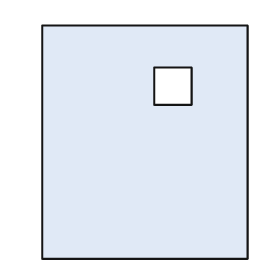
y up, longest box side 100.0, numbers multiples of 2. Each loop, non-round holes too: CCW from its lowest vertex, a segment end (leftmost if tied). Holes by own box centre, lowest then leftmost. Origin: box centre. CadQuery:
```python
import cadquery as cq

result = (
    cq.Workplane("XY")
    .moveTo(-44.0, -50.0)
    .lineTo(44.0, -50.0)
    .lineTo(44.0, 50.0)
    .lineTo(-44.0, 50.0)
    .close()
    .moveTo(4.0, 16.0)
    .lineTo(20.0, 16.0)
    .lineTo(20.0, 32.0)
    .lineTo(4.0, 32.0)
    .close()
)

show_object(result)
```